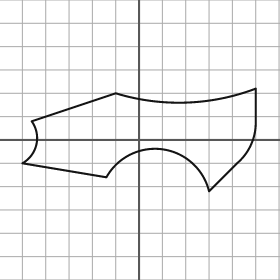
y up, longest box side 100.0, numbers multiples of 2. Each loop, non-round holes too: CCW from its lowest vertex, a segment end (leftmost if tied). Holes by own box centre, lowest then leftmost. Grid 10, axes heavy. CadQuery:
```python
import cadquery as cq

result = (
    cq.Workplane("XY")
    .moveTo(30.0, -22.0)
    .lineTo(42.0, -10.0)
    .threePointArc((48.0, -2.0), (50.0, 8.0))
    .lineTo(50.0, 22.0)
    .threePointArc((20.0, 16.0), (-10.0, 20.0))
    .lineTo(-46.0, 8.0)
    .threePointArc((-44.0, -2.0), (-50.0, -10.0))
    .lineTo(-14.0, -16.0)
    .threePointArc((10.0, -4.0), (30.0, -22.0))
    .close()
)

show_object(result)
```